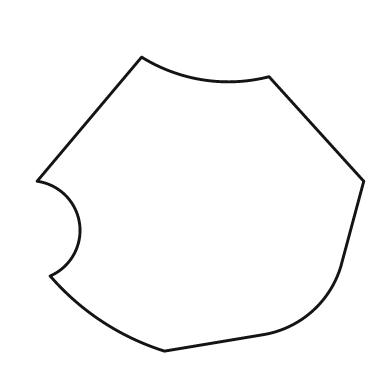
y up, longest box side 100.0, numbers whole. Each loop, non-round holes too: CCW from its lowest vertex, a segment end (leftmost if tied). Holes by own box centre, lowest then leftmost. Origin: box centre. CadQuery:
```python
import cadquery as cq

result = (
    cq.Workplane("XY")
    .moveTo(-11.0, -45.0)
    .lineTo(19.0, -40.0)
    .threePointArc((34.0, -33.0), (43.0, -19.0))
    .lineTo(50.0, 7.0)
    .lineTo(21.0, 39.0)
    .threePointArc((1.0, 38.0), (-18.0, 45.0))
    .lineTo(-50.0, 7.0)
    .threePointArc((-37.0, -6.0), (-46.0, -22.0))
    .threePointArc((-30.0, -36.0), (-11.0, -45.0))
    .close()
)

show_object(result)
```